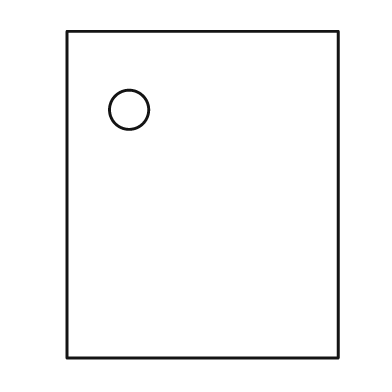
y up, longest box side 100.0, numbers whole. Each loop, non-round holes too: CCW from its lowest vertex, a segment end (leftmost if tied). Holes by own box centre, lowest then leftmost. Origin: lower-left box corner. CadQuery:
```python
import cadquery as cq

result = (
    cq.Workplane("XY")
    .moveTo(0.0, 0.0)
    .lineTo(83.0, 0.0)
    .lineTo(83.0, 100.0)
    .lineTo(0.0, 100.0)
    .close()
    .moveTo(19.0, 76.0)
    .circle(6.0)
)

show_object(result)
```